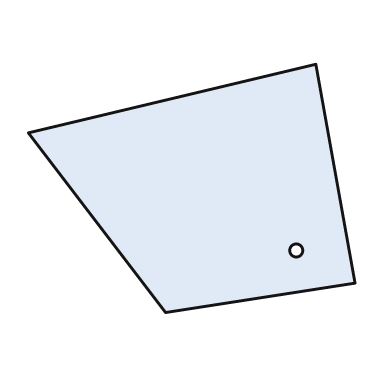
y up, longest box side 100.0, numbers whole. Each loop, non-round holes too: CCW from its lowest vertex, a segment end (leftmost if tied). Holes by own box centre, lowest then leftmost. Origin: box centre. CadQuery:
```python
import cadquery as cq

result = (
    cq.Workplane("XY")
    .moveTo(-8.0, -38.0)
    .lineTo(50.0, -29.0)
    .lineTo(38.0, 38.0)
    .lineTo(-50.0, 17.0)
    .close()
    .moveTo(32.0, -19.0)
    .circle(2.0)
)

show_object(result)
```